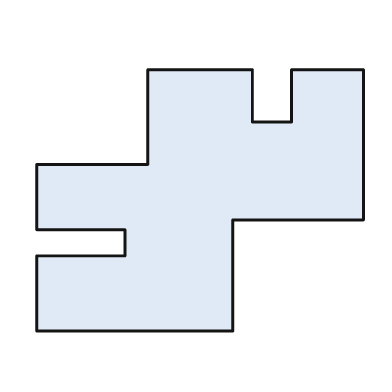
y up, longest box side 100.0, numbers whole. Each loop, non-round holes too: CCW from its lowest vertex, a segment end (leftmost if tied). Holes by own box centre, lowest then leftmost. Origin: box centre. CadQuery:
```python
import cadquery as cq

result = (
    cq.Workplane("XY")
    .moveTo(-50.0, -40.0)
    .lineTo(10.0, -40.0)
    .lineTo(10.0, -6.0)
    .lineTo(50.0, -6.0)
    .lineTo(50.0, 40.0)
    .lineTo(28.0, 40.0)
    .lineTo(28.0, 24.0)
    .lineTo(16.0, 24.0)
    .lineTo(16.0, 40.0)
    .lineTo(-16.0, 40.0)
    .lineTo(-16.0, 11.0)
    .lineTo(-50.0, 11.0)
    .lineTo(-50.0, -9.0)
    .lineTo(-23.0, -9.0)
    .lineTo(-23.0, -17.0)
    .lineTo(-50.0, -17.0)
    .close()
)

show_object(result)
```